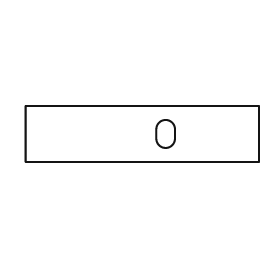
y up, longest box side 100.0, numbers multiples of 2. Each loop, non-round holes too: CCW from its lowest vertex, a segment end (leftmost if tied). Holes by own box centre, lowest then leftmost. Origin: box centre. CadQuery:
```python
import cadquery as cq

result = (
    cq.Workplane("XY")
    .moveTo(-50.0, -12.0)
    .lineTo(50.0, -12.0)
    .lineTo(50.0, 12.0)
    .lineTo(-50.0, 12.0)
    .close()
    .moveTo(6.0, -2.0)
    .threePointArc((10.0, -6.0), (14.0, -2.0))
    .lineTo(14.0, 2.0)
    .threePointArc((10.0, 6.0), (6.0, 2.0))
    .close()
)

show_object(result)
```